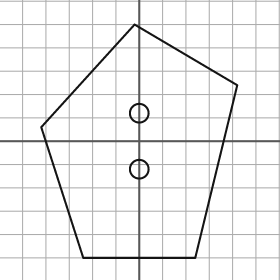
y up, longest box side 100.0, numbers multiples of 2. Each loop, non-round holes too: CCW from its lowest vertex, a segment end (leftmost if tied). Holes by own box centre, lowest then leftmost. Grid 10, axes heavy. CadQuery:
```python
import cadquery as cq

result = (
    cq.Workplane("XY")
    .moveTo(-24.0, -50.0)
    .lineTo(24.0, -50.0)
    .lineTo(42.0, 24.0)
    .lineTo(-2.0, 50.0)
    .lineTo(-42.0, 6.0)
    .close()
    .moveTo(0.0, -12.0)
    .circle(4.0)
    .moveTo(0.0, 12.0)
    .circle(4.0)
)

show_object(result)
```